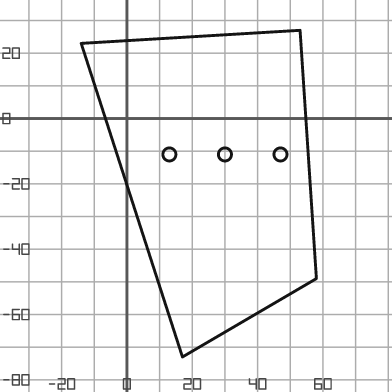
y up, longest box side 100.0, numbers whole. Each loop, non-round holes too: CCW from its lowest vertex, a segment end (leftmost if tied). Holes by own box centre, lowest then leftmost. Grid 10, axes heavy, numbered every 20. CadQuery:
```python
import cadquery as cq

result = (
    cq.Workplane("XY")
    .moveTo(17.0, -73.0)
    .lineTo(58.0, -49.0)
    .lineTo(53.0, 27.0)
    .lineTo(-14.0, 23.0)
    .close()
    .moveTo(13.0, -11.0)
    .circle(2.0)
    .moveTo(30.0, -11.0)
    .circle(2.0)
    .moveTo(47.0, -11.0)
    .circle(2.0)
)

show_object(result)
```